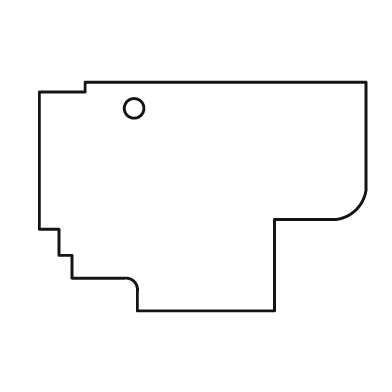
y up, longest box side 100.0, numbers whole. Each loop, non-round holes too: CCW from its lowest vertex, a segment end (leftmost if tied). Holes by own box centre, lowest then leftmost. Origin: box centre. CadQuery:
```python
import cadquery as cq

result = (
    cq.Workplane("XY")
    .moveTo(-20.0, -35.0)
    .lineTo(22.0, -35.0)
    .lineTo(22.0, -7.0)
    .lineTo(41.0, -7.0)
    .threePointArc((47.0, -4.0), (50.0, 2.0))
    .lineTo(50.0, 35.0)
    .lineTo(-36.0, 35.0)
    .lineTo(-36.0, 32.0)
    .lineTo(-50.0, 32.0)
    .lineTo(-50.0, -10.0)
    .lineTo(-44.0, -10.0)
    .lineTo(-44.0, -18.0)
    .lineTo(-40.0, -18.0)
    .lineTo(-40.0, -25.0)
    .lineTo(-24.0, -25.0)
    .threePointArc((-21.0, -26.0), (-20.0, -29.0))
    .close()
    .moveTo(-21.0, 27.0)
    .circle(3.0)
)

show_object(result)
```